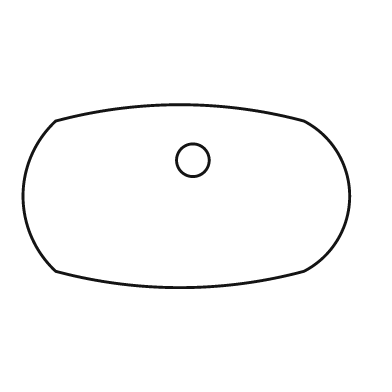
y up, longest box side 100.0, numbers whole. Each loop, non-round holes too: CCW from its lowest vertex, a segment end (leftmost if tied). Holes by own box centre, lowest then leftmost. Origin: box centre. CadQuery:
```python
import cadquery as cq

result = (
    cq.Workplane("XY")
    .moveTo(-40.0, -23.0)
    .threePointArc((-2.0, -28.0), (36.0, -23.0))
    .threePointArc((50.0, 0.0), (36.0, 23.0))
    .threePointArc((-2.0, 28.0), (-40.0, 23.0))
    .threePointArc((-50.0, 0.0), (-40.0, -23.0))
    .close()
    .moveTo(2.0, 11.0)
    .circle(5.0)
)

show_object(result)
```